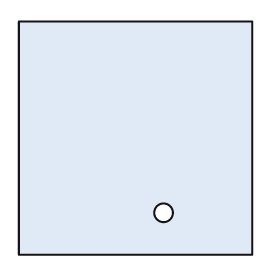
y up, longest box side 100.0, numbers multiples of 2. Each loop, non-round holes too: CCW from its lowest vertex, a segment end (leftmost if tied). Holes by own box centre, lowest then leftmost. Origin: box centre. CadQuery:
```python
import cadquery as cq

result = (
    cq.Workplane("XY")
    .moveTo(-50.0, -50.0)
    .lineTo(50.0, -50.0)
    .lineTo(50.0, 50.0)
    .lineTo(-50.0, 50.0)
    .close()
    .moveTo(12.0, -32.0)
    .circle(4.0)
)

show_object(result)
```